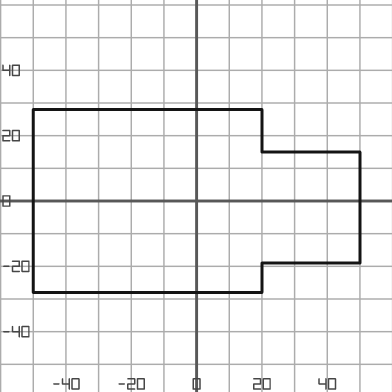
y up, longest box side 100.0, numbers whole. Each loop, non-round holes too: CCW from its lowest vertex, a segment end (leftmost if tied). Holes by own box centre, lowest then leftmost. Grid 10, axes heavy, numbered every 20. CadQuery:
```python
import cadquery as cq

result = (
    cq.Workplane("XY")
    .moveTo(-50.0, -28.0)
    .lineTo(20.0, -28.0)
    .lineTo(20.0, -19.0)
    .lineTo(50.0, -19.0)
    .lineTo(50.0, 15.0)
    .lineTo(20.0, 15.0)
    .lineTo(20.0, 28.0)
    .lineTo(-50.0, 28.0)
    .close()
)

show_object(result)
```